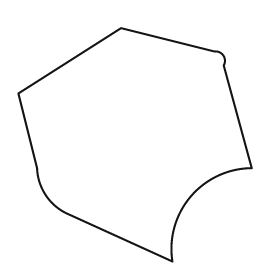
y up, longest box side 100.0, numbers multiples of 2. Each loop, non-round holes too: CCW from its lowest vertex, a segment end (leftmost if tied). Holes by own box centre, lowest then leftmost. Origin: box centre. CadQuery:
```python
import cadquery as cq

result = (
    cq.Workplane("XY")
    .moveTo(16.0, -50.0)
    .threePointArc((24.0, -22.0), (50.0, -10.0))
    .lineTo(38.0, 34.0)
    .threePointArc((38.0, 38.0), (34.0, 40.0))
    .lineTo(-6.0, 50.0)
    .lineTo(-50.0, 22.0)
    .lineTo(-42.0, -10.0)
    .threePointArc((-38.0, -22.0), (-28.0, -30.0))
    .close()
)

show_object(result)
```